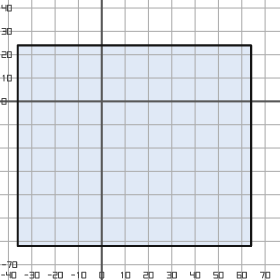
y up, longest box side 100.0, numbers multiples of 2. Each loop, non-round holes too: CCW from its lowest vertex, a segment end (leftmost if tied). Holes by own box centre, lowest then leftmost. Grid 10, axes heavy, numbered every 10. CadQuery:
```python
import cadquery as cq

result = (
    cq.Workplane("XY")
    .moveTo(-36.0, -62.0)
    .lineTo(64.0, -62.0)
    .lineTo(64.0, 24.0)
    .lineTo(-36.0, 24.0)
    .close()
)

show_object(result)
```